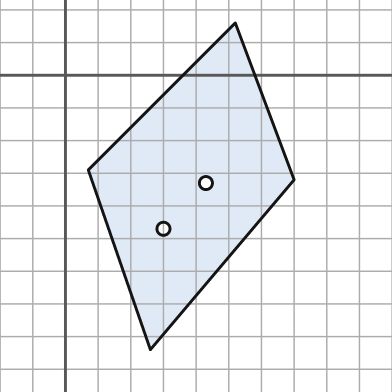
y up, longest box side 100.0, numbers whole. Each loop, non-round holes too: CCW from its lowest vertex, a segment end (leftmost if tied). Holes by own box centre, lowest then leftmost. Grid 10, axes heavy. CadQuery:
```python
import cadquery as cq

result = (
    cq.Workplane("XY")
    .moveTo(26.0, -84.0)
    .lineTo(70.0, -32.0)
    .lineTo(52.0, 16.0)
    .lineTo(7.0, -29.0)
    .close()
    .moveTo(30.0, -47.0)
    .circle(2.0)
    .moveTo(43.0, -33.0)
    .circle(2.0)
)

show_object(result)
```